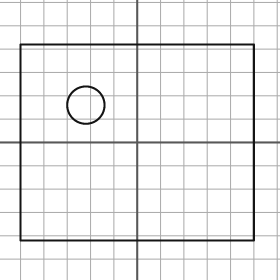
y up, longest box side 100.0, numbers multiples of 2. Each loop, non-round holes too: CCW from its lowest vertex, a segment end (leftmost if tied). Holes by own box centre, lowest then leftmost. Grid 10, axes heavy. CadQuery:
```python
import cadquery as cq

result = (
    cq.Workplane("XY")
    .moveTo(-50.0, -42.0)
    .lineTo(50.0, -42.0)
    .lineTo(50.0, 42.0)
    .lineTo(-50.0, 42.0)
    .close()
    .moveTo(-22.0, 16.0)
    .circle(8.0)
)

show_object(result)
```